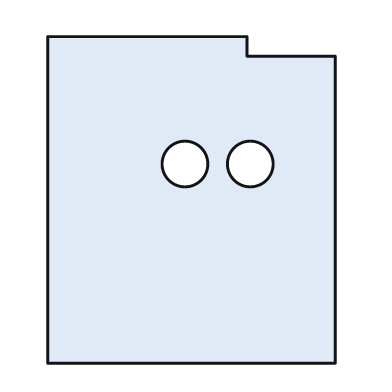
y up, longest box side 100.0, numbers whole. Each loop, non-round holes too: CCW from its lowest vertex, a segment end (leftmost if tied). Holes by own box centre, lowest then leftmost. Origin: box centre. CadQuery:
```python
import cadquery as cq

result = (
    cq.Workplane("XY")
    .moveTo(-44.0, -50.0)
    .lineTo(44.0, -50.0)
    .lineTo(44.0, 44.0)
    .lineTo(17.0, 44.0)
    .lineTo(17.0, 50.0)
    .lineTo(-44.0, 50.0)
    .close()
    .moveTo(-2.0, 11.0)
    .circle(7.0)
    .moveTo(18.0, 11.0)
    .circle(7.0)
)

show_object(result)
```